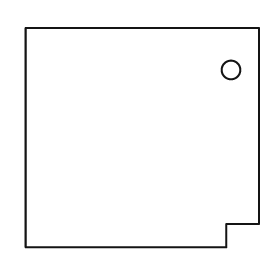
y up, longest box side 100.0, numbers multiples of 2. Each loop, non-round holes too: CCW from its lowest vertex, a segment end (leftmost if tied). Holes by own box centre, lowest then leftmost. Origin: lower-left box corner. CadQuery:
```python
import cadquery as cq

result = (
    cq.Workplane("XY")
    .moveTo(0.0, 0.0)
    .lineTo(86.0, 0.0)
    .lineTo(86.0, 10.0)
    .lineTo(100.0, 10.0)
    .lineTo(100.0, 94.0)
    .lineTo(0.0, 94.0)
    .close()
    .moveTo(88.0, 76.0)
    .circle(4.0)
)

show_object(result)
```